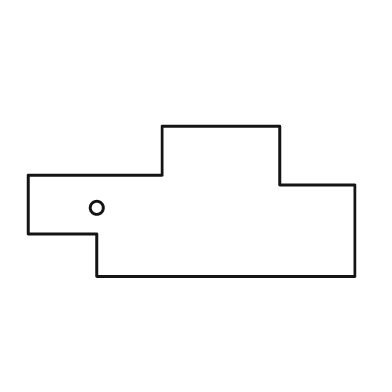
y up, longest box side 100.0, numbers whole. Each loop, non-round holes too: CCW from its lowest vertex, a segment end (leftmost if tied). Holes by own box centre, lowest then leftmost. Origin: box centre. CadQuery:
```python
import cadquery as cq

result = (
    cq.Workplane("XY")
    .moveTo(-29.0, -23.0)
    .lineTo(50.0, -23.0)
    .lineTo(50.0, 5.0)
    .lineTo(27.0, 5.0)
    .lineTo(27.0, 23.0)
    .lineTo(-9.0, 23.0)
    .lineTo(-9.0, 8.0)
    .lineTo(-50.0, 8.0)
    .lineTo(-50.0, -10.0)
    .lineTo(-29.0, -10.0)
    .close()
    .moveTo(-29.0, -2.0)
    .circle(2.0)
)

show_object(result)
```